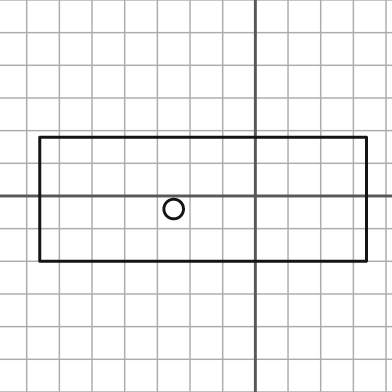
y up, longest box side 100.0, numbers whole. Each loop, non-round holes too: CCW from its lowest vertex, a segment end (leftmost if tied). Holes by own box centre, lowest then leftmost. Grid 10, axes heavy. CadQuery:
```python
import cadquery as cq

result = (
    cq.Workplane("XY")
    .moveTo(-66.0, -20.0)
    .lineTo(34.0, -20.0)
    .lineTo(34.0, 18.0)
    .lineTo(-66.0, 18.0)
    .close()
    .moveTo(-25.0, -4.0)
    .circle(3.0)
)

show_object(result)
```